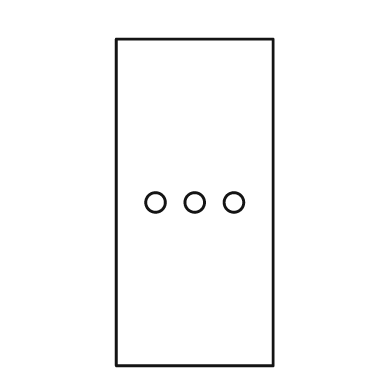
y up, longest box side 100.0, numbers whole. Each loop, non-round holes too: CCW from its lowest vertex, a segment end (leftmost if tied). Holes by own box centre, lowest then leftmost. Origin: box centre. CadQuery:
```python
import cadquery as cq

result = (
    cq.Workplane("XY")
    .moveTo(-24.0, -50.0)
    .lineTo(24.0, -50.0)
    .lineTo(24.0, 50.0)
    .lineTo(-24.0, 50.0)
    .close()
    .moveTo(-12.0, 0.0)
    .circle(3.0)
    .moveTo(0.0, 0.0)
    .circle(3.0)
    .moveTo(12.0, 0.0)
    .circle(3.0)
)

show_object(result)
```